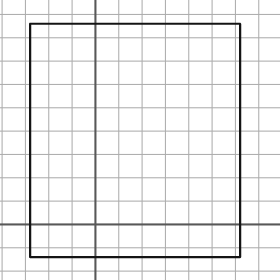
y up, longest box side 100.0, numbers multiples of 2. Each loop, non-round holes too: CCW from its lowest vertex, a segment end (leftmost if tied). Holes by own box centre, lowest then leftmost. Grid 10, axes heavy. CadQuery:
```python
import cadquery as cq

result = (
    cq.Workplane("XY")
    .moveTo(-28.0, -14.0)
    .lineTo(62.0, -14.0)
    .lineTo(62.0, 86.0)
    .lineTo(-28.0, 86.0)
    .close()
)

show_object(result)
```